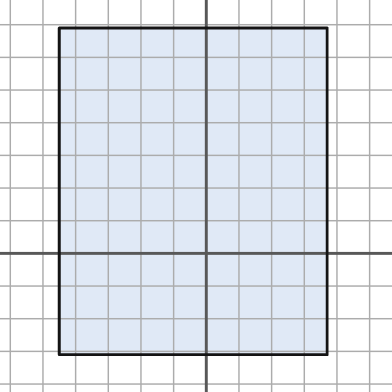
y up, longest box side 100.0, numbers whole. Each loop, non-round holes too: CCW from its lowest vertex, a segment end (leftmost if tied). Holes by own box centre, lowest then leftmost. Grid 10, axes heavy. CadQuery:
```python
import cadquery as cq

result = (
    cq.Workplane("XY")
    .moveTo(-45.0, -31.0)
    .lineTo(37.0, -31.0)
    .lineTo(37.0, 69.0)
    .lineTo(-45.0, 69.0)
    .close()
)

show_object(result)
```